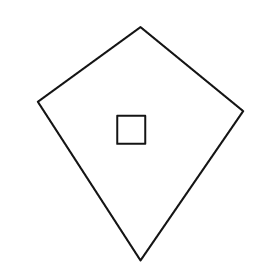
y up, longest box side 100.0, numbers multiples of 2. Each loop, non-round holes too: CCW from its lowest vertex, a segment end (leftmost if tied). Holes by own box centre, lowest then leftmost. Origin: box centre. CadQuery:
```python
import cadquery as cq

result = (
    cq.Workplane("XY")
    .moveTo(0.0, -50.0)
    .lineTo(44.0, 14.0)
    .lineTo(0.0, 50.0)
    .lineTo(-44.0, 18.0)
    .close()
    .moveTo(-10.0, 0.0)
    .lineTo(2.0, 0.0)
    .lineTo(2.0, 12.0)
    .lineTo(-10.0, 12.0)
    .close()
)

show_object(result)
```